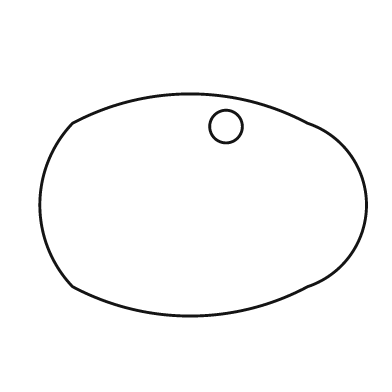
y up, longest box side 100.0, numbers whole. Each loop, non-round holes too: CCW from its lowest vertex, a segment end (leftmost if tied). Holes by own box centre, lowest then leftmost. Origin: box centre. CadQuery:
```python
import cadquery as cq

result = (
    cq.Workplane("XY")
    .moveTo(-40.0, -25.0)
    .threePointArc((-4.0, -34.0), (32.0, -25.0))
    .threePointArc((50.0, 0.0), (32.0, 25.0))
    .threePointArc((-4.0, 34.0), (-40.0, 25.0))
    .threePointArc((-50.0, 0.0), (-40.0, -25.0))
    .close()
    .moveTo(7.0, 24.0)
    .circle(5.0)
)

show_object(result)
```